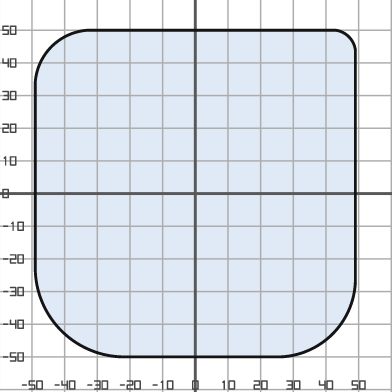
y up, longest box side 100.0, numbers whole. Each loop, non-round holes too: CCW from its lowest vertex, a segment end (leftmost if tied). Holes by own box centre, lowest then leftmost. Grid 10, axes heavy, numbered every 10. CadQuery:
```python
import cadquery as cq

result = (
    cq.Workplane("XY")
    .moveTo(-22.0, -50.0)
    .lineTo(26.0, -50.0)
    .threePointArc((42.0, -43.0), (49.0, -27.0))
    .lineTo(49.0, 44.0)
    .threePointArc((47.0, 48.0), (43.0, 50.0))
    .lineTo(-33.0, 50.0)
    .threePointArc((-44.0, 45.0), (-49.0, 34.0))
    .lineTo(-49.0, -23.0)
    .threePointArc((-41.0, -42.0), (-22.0, -50.0))
    .close()
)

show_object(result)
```